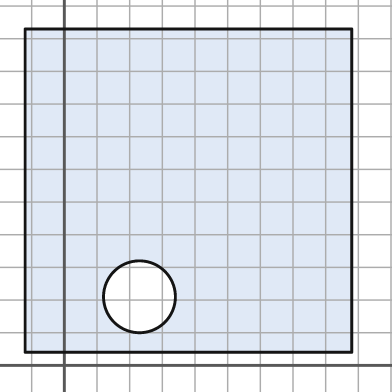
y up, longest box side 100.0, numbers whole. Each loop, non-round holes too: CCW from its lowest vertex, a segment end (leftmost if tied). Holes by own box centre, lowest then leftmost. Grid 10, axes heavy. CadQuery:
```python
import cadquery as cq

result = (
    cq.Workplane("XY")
    .moveTo(-12.0, 4.0)
    .lineTo(88.0, 4.0)
    .lineTo(88.0, 103.0)
    .lineTo(-12.0, 103.0)
    .close()
    .moveTo(23.0, 21.0)
    .circle(11.0)
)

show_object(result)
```